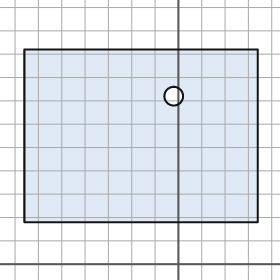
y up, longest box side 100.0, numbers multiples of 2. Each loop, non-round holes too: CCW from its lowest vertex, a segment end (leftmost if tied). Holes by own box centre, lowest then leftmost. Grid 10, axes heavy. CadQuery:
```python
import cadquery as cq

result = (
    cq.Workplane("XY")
    .moveTo(-66.0, 18.0)
    .lineTo(34.0, 18.0)
    .lineTo(34.0, 92.0)
    .lineTo(-66.0, 92.0)
    .close()
    .moveTo(-2.0, 72.0)
    .circle(4.0)
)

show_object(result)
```